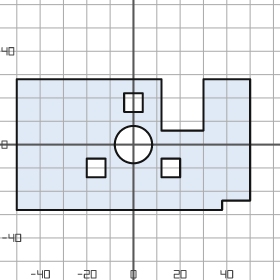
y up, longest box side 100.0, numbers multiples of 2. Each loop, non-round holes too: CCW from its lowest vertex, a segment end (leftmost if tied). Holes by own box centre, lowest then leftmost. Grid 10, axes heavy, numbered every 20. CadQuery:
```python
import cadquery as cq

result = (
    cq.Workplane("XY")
    .moveTo(-50.0, -28.0)
    .lineTo(38.0, -28.0)
    .lineTo(38.0, -24.0)
    .lineTo(50.0, -24.0)
    .lineTo(50.0, 28.0)
    .lineTo(30.0, 28.0)
    .lineTo(30.0, 6.0)
    .lineTo(12.0, 6.0)
    .lineTo(12.0, 28.0)
    .lineTo(-50.0, 28.0)
    .close()
    .moveTo(-20.0, -14.0)
    .lineTo(-12.0, -14.0)
    .lineTo(-12.0, -6.0)
    .lineTo(-20.0, -6.0)
    .close()
    .moveTo(12.0, -14.0)
    .lineTo(20.0, -14.0)
    .lineTo(20.0, -6.0)
    .lineTo(12.0, -6.0)
    .close()
    .moveTo(0.0, 0.0)
    .circle(8.0)
    .moveTo(-4.0, 14.0)
    .lineTo(4.0, 14.0)
    .lineTo(4.0, 22.0)
    .lineTo(-4.0, 22.0)
    .close()
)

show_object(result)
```